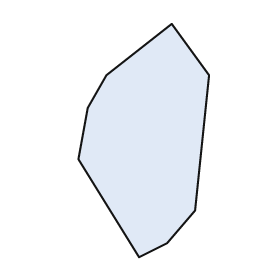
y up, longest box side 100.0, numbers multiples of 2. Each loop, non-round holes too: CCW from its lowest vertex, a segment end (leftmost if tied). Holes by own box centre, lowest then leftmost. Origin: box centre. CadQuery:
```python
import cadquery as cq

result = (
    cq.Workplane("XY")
    .moveTo(-2.0, -50.0)
    .lineTo(10.0, -44.0)
    .lineTo(22.0, -30.0)
    .lineTo(28.0, 28.0)
    .lineTo(12.0, 50.0)
    .lineTo(-16.0, 28.0)
    .lineTo(-24.0, 14.0)
    .lineTo(-28.0, -8.0)
    .close()
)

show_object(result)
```